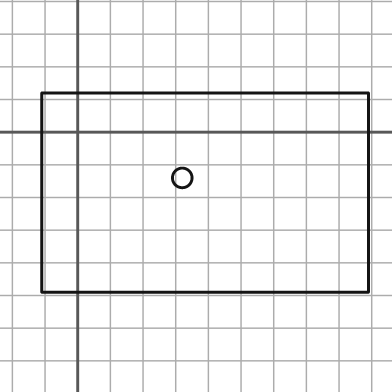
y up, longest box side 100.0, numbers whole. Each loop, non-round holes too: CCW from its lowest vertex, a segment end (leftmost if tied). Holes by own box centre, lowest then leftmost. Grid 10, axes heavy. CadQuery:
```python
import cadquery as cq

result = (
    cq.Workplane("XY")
    .moveTo(-11.0, -49.0)
    .lineTo(89.0, -49.0)
    .lineTo(89.0, 12.0)
    .lineTo(-11.0, 12.0)
    .close()
    .moveTo(32.0, -14.0)
    .circle(3.0)
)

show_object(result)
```